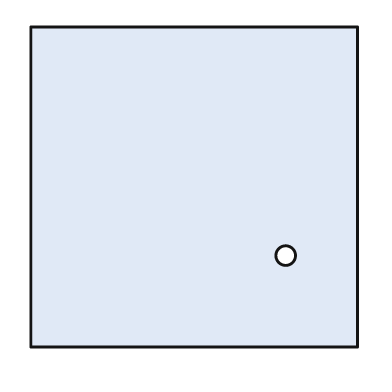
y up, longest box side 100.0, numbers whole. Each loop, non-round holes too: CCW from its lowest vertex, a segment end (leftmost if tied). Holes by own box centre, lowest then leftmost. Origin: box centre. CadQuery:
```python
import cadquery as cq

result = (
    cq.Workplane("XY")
    .moveTo(-50.0, -49.0)
    .lineTo(50.0, -49.0)
    .lineTo(50.0, 49.0)
    .lineTo(-50.0, 49.0)
    .close()
    .moveTo(28.0, -21.0)
    .circle(3.0)
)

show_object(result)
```